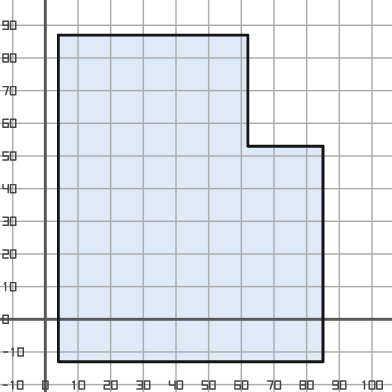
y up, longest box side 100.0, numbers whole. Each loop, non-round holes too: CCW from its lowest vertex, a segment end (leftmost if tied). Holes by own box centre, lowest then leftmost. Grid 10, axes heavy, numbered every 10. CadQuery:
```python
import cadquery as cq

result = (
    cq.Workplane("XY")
    .moveTo(4.0, -13.0)
    .lineTo(85.0, -13.0)
    .lineTo(85.0, 53.0)
    .lineTo(62.0, 53.0)
    .lineTo(62.0, 87.0)
    .lineTo(4.0, 87.0)
    .close()
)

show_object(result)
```